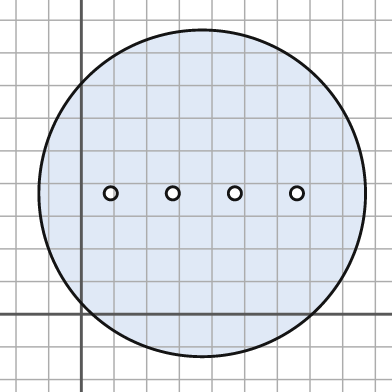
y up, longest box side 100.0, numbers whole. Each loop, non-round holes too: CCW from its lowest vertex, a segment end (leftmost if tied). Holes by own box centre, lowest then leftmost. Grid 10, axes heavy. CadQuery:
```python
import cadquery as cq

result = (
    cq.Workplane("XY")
    .moveTo(37.0, 37.0)
    .circle(50.0)
    .moveTo(9.0, 37.0)
    .circle(2.0)
    .moveTo(28.0, 37.0)
    .circle(2.0)
    .moveTo(47.0, 37.0)
    .circle(2.0)
    .moveTo(66.0, 37.0)
    .circle(2.0)
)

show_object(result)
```